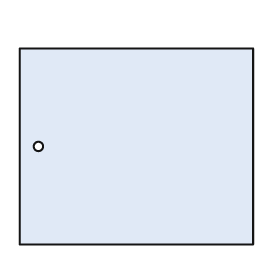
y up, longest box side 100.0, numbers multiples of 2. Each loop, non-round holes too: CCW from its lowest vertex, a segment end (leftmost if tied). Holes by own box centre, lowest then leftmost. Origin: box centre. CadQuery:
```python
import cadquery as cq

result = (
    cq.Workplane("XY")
    .moveTo(-50.0, -42.0)
    .lineTo(50.0, -42.0)
    .lineTo(50.0, 42.0)
    .lineTo(-50.0, 42.0)
    .close()
    .moveTo(-42.0, 0.0)
    .circle(2.0)
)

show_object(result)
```